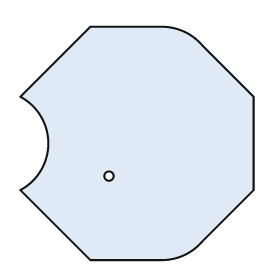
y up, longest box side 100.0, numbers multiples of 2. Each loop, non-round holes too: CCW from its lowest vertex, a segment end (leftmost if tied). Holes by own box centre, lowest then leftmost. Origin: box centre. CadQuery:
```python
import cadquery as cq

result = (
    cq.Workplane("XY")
    .moveTo(-20.0, -50.0)
    .lineTo(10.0, -50.0)
    .threePointArc((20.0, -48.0), (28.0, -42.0))
    .lineTo(50.0, -20.0)
    .lineTo(50.0, 20.0)
    .lineTo(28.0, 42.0)
    .threePointArc((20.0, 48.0), (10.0, 50.0))
    .lineTo(-20.0, 50.0)
    .lineTo(-50.0, 20.0)
    .threePointArc((-38.0, 0.0), (-50.0, -20.0))
    .close()
    .moveTo(-12.0, -14.0)
    .circle(2.0)
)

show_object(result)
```